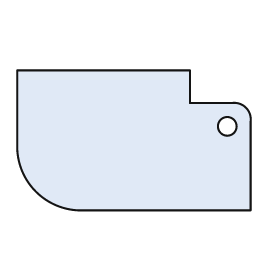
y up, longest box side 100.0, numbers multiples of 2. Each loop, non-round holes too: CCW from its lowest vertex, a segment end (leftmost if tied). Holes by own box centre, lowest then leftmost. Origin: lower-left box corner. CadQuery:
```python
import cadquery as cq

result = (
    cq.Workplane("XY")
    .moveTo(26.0, 0.0)
    .lineTo(100.0, 0.0)
    .lineTo(100.0, 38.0)
    .threePointArc((98.0, 44.0), (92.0, 46.0))
    .lineTo(74.0, 46.0)
    .lineTo(74.0, 60.0)
    .lineTo(0.0, 60.0)
    .lineTo(0.0, 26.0)
    .threePointArc((8.0, 8.0), (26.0, 0.0))
    .close()
    .moveTo(90.0, 36.0)
    .circle(4.0)
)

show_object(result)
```